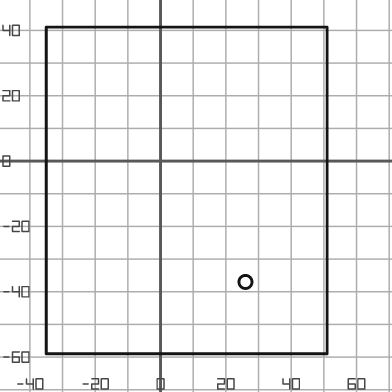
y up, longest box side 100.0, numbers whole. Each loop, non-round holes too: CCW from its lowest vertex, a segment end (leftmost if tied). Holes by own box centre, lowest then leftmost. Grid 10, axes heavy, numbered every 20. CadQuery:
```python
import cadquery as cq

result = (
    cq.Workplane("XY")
    .moveTo(-35.0, -59.0)
    .lineTo(51.0, -59.0)
    .lineTo(51.0, 41.0)
    .lineTo(-35.0, 41.0)
    .close()
    .moveTo(26.0, -37.0)
    .circle(2.0)
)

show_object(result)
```